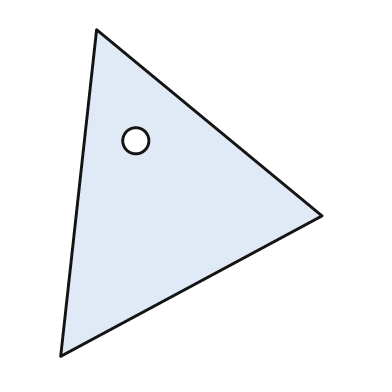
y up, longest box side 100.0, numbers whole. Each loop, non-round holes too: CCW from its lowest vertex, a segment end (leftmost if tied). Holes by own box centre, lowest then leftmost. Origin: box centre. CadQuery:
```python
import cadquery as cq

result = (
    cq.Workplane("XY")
    .moveTo(-40.0, -50.0)
    .lineTo(40.0, -7.0)
    .lineTo(-29.0, 50.0)
    .close()
    .moveTo(-17.0, 16.0)
    .circle(4.0)
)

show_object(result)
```